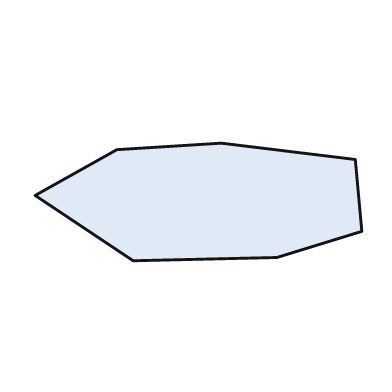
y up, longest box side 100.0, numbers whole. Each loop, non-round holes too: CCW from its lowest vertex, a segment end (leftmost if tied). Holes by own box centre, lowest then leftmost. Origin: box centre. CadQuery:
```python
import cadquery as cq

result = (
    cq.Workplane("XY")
    .moveTo(-20.0, -18.0)
    .lineTo(24.0, -17.0)
    .lineTo(50.0, -9.0)
    .lineTo(48.0, 13.0)
    .lineTo(7.0, 18.0)
    .lineTo(-25.0, 16.0)
    .lineTo(-50.0, 2.0)
    .close()
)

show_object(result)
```